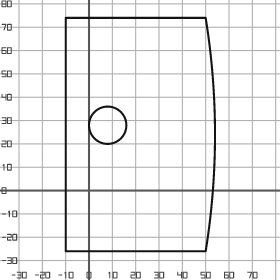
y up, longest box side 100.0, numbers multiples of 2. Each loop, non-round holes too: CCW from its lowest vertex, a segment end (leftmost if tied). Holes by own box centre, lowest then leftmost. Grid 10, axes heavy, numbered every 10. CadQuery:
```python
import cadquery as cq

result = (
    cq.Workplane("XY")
    .moveTo(-10.0, -26.0)
    .lineTo(50.0, -26.0)
    .threePointArc((54.0, 24.0), (50.0, 74.0))
    .lineTo(-10.0, 74.0)
    .close()
    .moveTo(8.0, 28.0)
    .circle(8.0)
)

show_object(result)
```